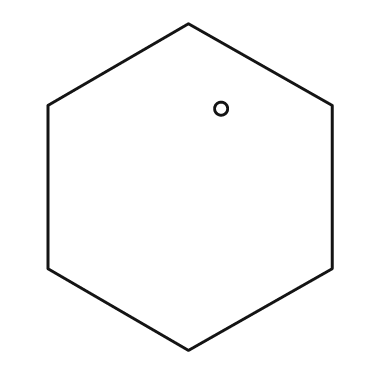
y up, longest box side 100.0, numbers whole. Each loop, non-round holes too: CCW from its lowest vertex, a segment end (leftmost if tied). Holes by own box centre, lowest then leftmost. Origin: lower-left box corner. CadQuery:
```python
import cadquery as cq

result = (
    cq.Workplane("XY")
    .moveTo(43.0, 0.0)
    .lineTo(87.0, 25.0)
    .lineTo(87.0, 75.0)
    .lineTo(43.0, 100.0)
    .lineTo(0.0, 75.0)
    .lineTo(0.0, 25.0)
    .close()
    .moveTo(53.0, 74.0)
    .circle(2.0)
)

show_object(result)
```